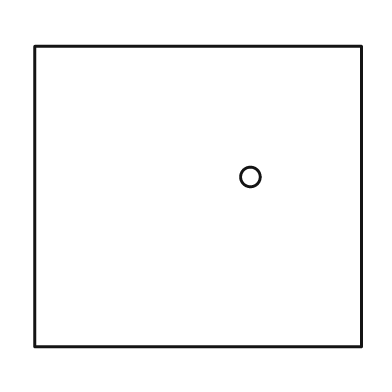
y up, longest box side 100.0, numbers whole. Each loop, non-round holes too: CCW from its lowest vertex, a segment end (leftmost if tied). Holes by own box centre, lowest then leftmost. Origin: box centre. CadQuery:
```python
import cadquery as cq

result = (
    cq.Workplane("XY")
    .moveTo(-50.0, -46.0)
    .lineTo(50.0, -46.0)
    .lineTo(50.0, 46.0)
    .lineTo(-50.0, 46.0)
    .close()
    .moveTo(16.0, 6.0)
    .circle(3.0)
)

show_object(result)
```